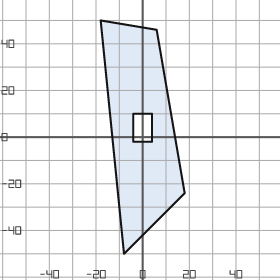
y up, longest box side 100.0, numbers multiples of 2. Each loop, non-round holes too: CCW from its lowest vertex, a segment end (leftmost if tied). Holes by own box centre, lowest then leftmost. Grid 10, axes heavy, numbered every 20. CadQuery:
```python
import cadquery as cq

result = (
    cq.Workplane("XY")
    .moveTo(-8.0, -50.0)
    .lineTo(18.0, -24.0)
    .lineTo(6.0, 46.0)
    .lineTo(-18.0, 50.0)
    .close()
    .moveTo(-4.0, -2.0)
    .lineTo(4.0, -2.0)
    .lineTo(4.0, 10.0)
    .lineTo(-4.0, 10.0)
    .close()
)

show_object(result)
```